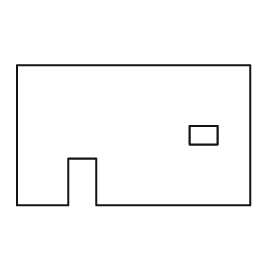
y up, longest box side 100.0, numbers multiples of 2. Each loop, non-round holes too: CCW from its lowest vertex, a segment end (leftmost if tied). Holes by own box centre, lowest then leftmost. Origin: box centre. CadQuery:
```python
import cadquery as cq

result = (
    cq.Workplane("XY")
    .moveTo(-50.0, -30.0)
    .lineTo(-28.0, -30.0)
    .lineTo(-28.0, -10.0)
    .lineTo(-16.0, -10.0)
    .lineTo(-16.0, -30.0)
    .lineTo(50.0, -30.0)
    .lineTo(50.0, 30.0)
    .lineTo(-50.0, 30.0)
    .close()
    .moveTo(24.0, -4.0)
    .lineTo(36.0, -4.0)
    .lineTo(36.0, 4.0)
    .lineTo(24.0, 4.0)
    .close()
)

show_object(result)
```